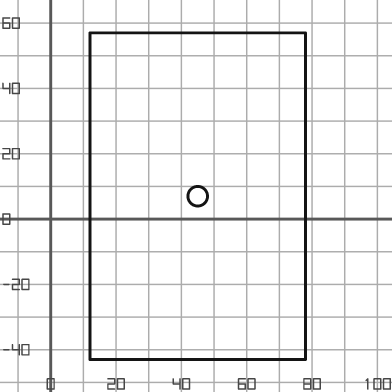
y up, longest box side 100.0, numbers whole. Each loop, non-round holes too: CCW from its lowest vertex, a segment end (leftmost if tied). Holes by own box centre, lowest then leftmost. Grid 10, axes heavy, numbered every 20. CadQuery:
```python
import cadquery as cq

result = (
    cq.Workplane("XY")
    .moveTo(12.0, -43.0)
    .lineTo(78.0, -43.0)
    .lineTo(78.0, 57.0)
    .lineTo(12.0, 57.0)
    .close()
    .moveTo(45.0, 7.0)
    .circle(3.0)
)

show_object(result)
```